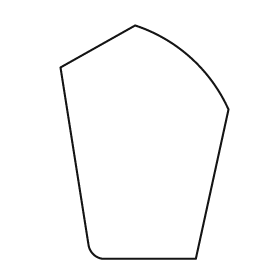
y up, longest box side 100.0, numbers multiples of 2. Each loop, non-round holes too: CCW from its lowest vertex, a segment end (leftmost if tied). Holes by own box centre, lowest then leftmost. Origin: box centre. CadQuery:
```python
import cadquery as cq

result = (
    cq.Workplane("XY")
    .moveTo(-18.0, -50.0)
    .lineTo(22.0, -50.0)
    .lineTo(36.0, 14.0)
    .threePointArc((20.0, 36.0), (-4.0, 50.0))
    .lineTo(-36.0, 32.0)
    .lineTo(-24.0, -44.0)
    .threePointArc((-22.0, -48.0), (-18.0, -50.0))
    .close()
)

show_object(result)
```